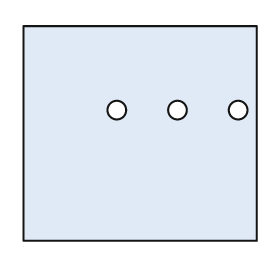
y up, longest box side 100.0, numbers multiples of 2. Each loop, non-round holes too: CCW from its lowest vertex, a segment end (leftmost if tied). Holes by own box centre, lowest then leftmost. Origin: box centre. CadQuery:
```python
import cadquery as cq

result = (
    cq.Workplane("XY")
    .moveTo(-50.0, -46.0)
    .lineTo(50.0, -46.0)
    .lineTo(50.0, 46.0)
    .lineTo(-50.0, 46.0)
    .close()
    .moveTo(-10.0, 10.0)
    .circle(4.0)
    .moveTo(16.0, 10.0)
    .circle(4.0)
    .moveTo(42.0, 10.0)
    .circle(4.0)
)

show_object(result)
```